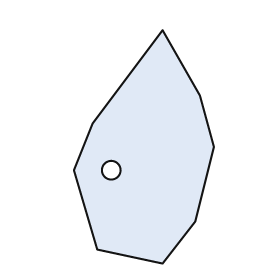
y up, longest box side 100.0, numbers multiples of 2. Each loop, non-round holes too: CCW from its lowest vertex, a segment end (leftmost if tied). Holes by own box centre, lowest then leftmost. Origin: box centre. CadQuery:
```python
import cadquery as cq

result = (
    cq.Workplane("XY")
    .moveTo(8.0, -50.0)
    .lineTo(22.0, -32.0)
    .lineTo(30.0, 0.0)
    .lineTo(24.0, 22.0)
    .lineTo(8.0, 50.0)
    .lineTo(-22.0, 10.0)
    .lineTo(-30.0, -10.0)
    .lineTo(-20.0, -44.0)
    .close()
    .moveTo(-14.0, -10.0)
    .circle(4.0)
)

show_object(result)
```